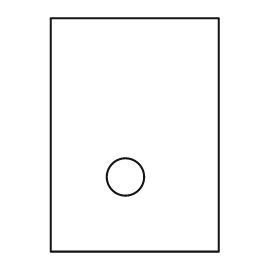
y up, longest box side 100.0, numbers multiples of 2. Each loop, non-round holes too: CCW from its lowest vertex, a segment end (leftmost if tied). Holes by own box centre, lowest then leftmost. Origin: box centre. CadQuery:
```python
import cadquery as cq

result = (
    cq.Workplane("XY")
    .moveTo(-36.0, -50.0)
    .lineTo(36.0, -50.0)
    .lineTo(36.0, 50.0)
    .lineTo(-36.0, 50.0)
    .close()
    .moveTo(-4.0, -18.0)
    .circle(8.0)
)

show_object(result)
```